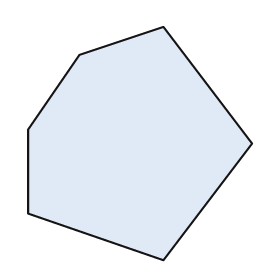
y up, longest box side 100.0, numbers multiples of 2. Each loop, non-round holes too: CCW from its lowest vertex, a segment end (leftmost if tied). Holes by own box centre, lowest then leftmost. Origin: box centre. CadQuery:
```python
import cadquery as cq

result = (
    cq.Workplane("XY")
    .moveTo(10.0, -50.0)
    .lineTo(48.0, 0.0)
    .lineTo(10.0, 50.0)
    .lineTo(-26.0, 38.0)
    .lineTo(-48.0, 6.0)
    .lineTo(-48.0, -30.0)
    .close()
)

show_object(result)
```